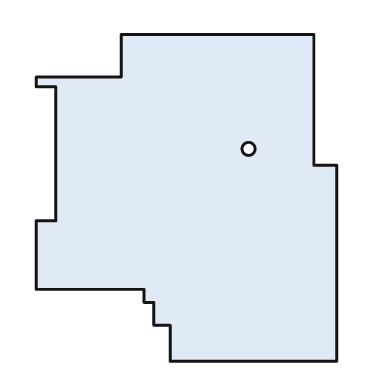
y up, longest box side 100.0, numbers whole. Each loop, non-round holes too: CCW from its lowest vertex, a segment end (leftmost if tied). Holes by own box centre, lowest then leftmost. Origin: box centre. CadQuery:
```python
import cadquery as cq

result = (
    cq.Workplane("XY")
    .moveTo(-5.0, -50.0)
    .lineTo(46.0, -50.0)
    .lineTo(46.0, 10.0)
    .lineTo(39.0, 10.0)
    .lineTo(39.0, 50.0)
    .lineTo(-20.0, 50.0)
    .lineTo(-20.0, 37.0)
    .lineTo(-46.0, 37.0)
    .lineTo(-46.0, 34.0)
    .lineTo(-40.0, 34.0)
    .lineTo(-40.0, -7.0)
    .lineTo(-46.0, -7.0)
    .lineTo(-46.0, -28.0)
    .lineTo(-13.0, -28.0)
    .lineTo(-13.0, -32.0)
    .lineTo(-10.0, -32.0)
    .lineTo(-10.0, -39.0)
    .lineTo(-5.0, -39.0)
    .close()
    .moveTo(19.0, 15.0)
    .circle(2.0)
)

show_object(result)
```